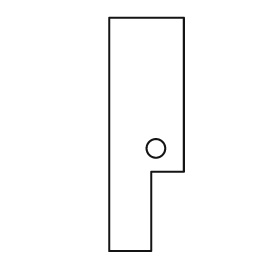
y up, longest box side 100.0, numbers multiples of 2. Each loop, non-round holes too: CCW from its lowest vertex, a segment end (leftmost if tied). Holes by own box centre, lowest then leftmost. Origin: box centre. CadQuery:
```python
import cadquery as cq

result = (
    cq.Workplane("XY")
    .moveTo(-16.0, -50.0)
    .lineTo(2.0, -50.0)
    .lineTo(2.0, -16.0)
    .lineTo(16.0, -16.0)
    .lineTo(16.0, 50.0)
    .lineTo(-16.0, 50.0)
    .close()
    .moveTo(4.0, -6.0)
    .circle(4.0)
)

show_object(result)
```